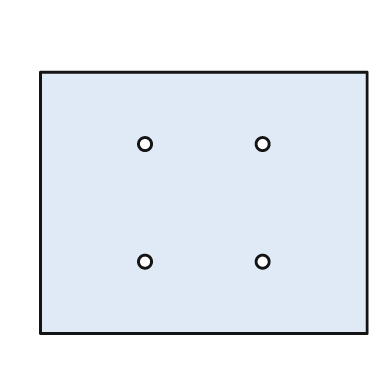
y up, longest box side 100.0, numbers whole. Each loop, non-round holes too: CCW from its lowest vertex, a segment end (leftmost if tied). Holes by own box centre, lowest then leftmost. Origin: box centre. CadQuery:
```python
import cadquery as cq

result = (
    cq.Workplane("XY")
    .moveTo(-50.0, -40.0)
    .lineTo(50.0, -40.0)
    .lineTo(50.0, 40.0)
    .lineTo(-50.0, 40.0)
    .close()
    .moveTo(-18.0, -18.0)
    .circle(2.0)
    .moveTo(18.0, -18.0)
    .circle(2.0)
    .moveTo(-18.0, 18.0)
    .circle(2.0)
    .moveTo(18.0, 18.0)
    .circle(2.0)
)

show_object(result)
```